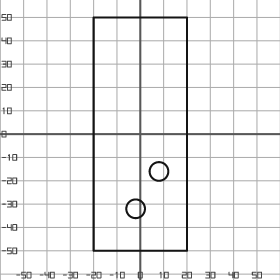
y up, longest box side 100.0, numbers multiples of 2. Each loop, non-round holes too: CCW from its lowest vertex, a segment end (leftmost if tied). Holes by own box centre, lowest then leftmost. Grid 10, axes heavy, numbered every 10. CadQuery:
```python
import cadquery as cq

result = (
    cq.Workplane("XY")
    .moveTo(-20.0, -50.0)
    .lineTo(20.0, -50.0)
    .lineTo(20.0, 50.0)
    .lineTo(-20.0, 50.0)
    .close()
    .moveTo(-2.0, -32.0)
    .circle(4.0)
    .moveTo(8.0, -16.0)
    .circle(4.0)
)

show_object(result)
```